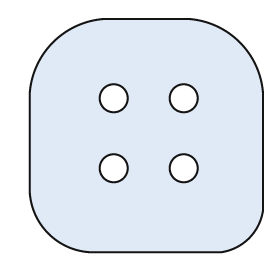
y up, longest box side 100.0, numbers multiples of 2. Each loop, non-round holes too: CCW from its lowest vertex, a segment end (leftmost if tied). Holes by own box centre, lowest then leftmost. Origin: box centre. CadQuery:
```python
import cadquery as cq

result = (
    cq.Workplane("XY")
    .moveTo(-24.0, -50.0)
    .lineTo(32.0, -50.0)
    .threePointArc((44.0, -44.0), (50.0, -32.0))
    .lineTo(50.0, 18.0)
    .threePointArc((40.0, 40.0), (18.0, 50.0))
    .lineTo(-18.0, 50.0)
    .threePointArc((-40.0, 40.0), (-50.0, 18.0))
    .lineTo(-50.0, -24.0)
    .threePointArc((-42.0, -42.0), (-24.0, -50.0))
    .close()
    .moveTo(-14.0, -14.0)
    .circle(6.0)
    .moveTo(16.0, -14.0)
    .circle(6.0)
    .moveTo(-14.0, 16.0)
    .circle(6.0)
    .moveTo(16.0, 16.0)
    .circle(6.0)
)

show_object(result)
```